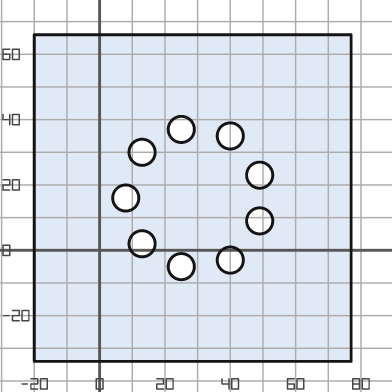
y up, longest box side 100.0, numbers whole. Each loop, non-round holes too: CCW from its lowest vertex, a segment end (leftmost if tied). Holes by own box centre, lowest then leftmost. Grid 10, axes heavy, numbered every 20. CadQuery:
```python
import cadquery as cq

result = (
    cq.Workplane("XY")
    .moveTo(-20.0, -34.0)
    .lineTo(77.0, -34.0)
    .lineTo(77.0, 66.0)
    .lineTo(-20.0, 66.0)
    .close()
    .moveTo(25.0, -5.0)
    .circle(4.0)
    .moveTo(40.0, -3.0)
    .circle(4.0)
    .moveTo(13.0, 2.0)
    .circle(4.0)
    .moveTo(49.0, 9.0)
    .circle(4.0)
    .moveTo(8.0, 16.0)
    .circle(4.0)
    .moveTo(49.0, 23.0)
    .circle(4.0)
    .moveTo(13.0, 30.0)
    .circle(4.0)
    .moveTo(40.0, 35.0)
    .circle(4.0)
    .moveTo(25.0, 37.0)
    .circle(4.0)
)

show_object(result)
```